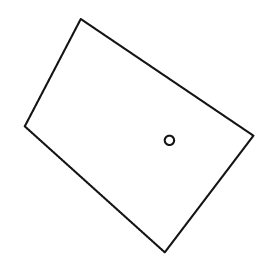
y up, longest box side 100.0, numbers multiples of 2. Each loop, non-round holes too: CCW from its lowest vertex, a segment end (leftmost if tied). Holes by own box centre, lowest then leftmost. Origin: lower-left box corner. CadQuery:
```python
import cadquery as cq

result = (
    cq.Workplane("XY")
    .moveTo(60.0, 0.0)
    .lineTo(98.0, 50.0)
    .lineTo(24.0, 100.0)
    .lineTo(0.0, 54.0)
    .close()
    .moveTo(62.0, 48.0)
    .circle(2.0)
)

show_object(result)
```